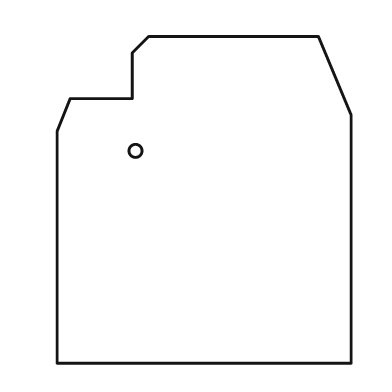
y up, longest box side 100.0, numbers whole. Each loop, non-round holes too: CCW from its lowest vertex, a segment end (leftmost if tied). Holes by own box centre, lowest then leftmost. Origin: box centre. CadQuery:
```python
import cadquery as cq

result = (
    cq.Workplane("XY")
    .moveTo(-45.0, -50.0)
    .lineTo(45.0, -50.0)
    .lineTo(45.0, 26.0)
    .lineTo(35.0, 50.0)
    .lineTo(-17.0, 50.0)
    .lineTo(-22.0, 45.0)
    .lineTo(-22.0, 31.0)
    .lineTo(-41.0, 31.0)
    .lineTo(-45.0, 21.0)
    .close()
    .moveTo(-21.0, 15.0)
    .circle(2.0)
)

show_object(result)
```